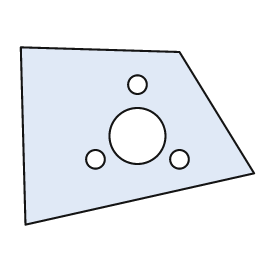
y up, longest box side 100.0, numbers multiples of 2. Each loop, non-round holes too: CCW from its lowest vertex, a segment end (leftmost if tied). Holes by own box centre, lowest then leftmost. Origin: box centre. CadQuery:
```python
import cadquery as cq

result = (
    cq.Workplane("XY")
    .moveTo(-48.0, -38.0)
    .lineTo(50.0, -16.0)
    .lineTo(18.0, 36.0)
    .lineTo(-50.0, 38.0)
    .close()
    .moveTo(-18.0, -10.0)
    .circle(4.0)
    .moveTo(18.0, -10.0)
    .circle(4.0)
    .moveTo(0.0, 0.0)
    .circle(12.0)
    .moveTo(0.0, 22.0)
    .circle(4.0)
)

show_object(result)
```